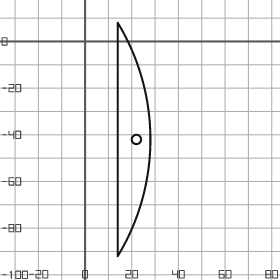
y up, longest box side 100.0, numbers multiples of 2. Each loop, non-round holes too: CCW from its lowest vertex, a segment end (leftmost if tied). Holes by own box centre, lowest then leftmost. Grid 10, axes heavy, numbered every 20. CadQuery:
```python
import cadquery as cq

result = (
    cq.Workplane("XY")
    .moveTo(14.0, -92.0)
    .threePointArc((28.0, -42.0), (14.0, 8.0))
    .close()
    .moveTo(22.0, -42.0)
    .circle(2.0)
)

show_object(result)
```